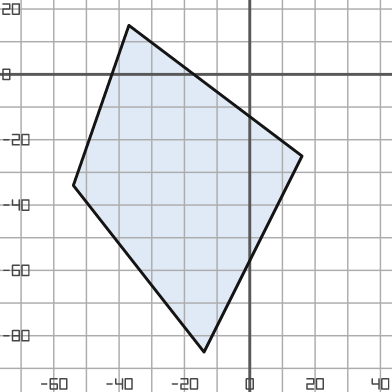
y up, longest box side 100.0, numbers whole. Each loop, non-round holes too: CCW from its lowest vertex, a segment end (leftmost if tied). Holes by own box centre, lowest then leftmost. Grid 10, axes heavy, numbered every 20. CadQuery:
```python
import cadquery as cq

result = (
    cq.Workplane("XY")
    .moveTo(-14.0, -85.0)
    .lineTo(16.0, -25.0)
    .lineTo(-37.0, 15.0)
    .lineTo(-54.0, -34.0)
    .close()
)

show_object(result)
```